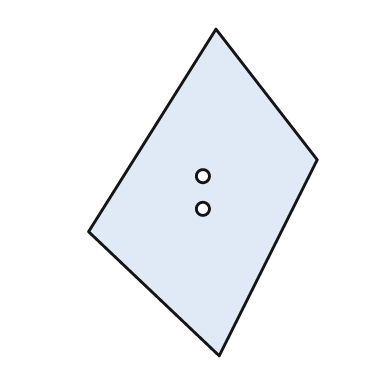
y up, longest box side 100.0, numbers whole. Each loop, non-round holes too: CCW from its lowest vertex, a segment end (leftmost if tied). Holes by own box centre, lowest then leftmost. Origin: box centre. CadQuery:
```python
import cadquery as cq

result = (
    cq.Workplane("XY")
    .moveTo(5.0, -50.0)
    .lineTo(35.0, 10.0)
    .lineTo(4.0, 50.0)
    .lineTo(-35.0, -12.0)
    .close()
    .moveTo(0.0, -5.0)
    .circle(2.0)
    .moveTo(0.0, 5.0)
    .circle(2.0)
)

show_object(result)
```